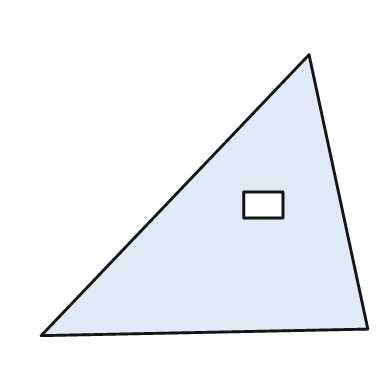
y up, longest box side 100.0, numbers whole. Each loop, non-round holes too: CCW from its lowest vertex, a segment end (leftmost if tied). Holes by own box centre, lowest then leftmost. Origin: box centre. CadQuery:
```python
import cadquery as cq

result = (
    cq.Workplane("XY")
    .moveTo(-50.0, -43.0)
    .lineTo(50.0, -41.0)
    .lineTo(32.0, 43.0)
    .close()
    .moveTo(12.0, -7.0)
    .lineTo(24.0, -7.0)
    .lineTo(24.0, 1.0)
    .lineTo(12.0, 1.0)
    .close()
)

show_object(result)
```